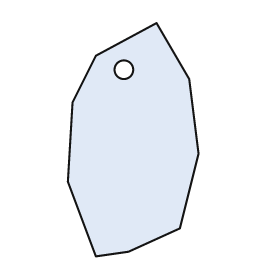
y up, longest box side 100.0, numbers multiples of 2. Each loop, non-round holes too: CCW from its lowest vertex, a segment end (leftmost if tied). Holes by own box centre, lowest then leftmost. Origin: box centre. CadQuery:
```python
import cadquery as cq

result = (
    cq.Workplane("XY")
    .moveTo(-16.0, -50.0)
    .lineTo(-2.0, -48.0)
    .lineTo(20.0, -38.0)
    .lineTo(28.0, -6.0)
    .lineTo(24.0, 26.0)
    .lineTo(10.0, 50.0)
    .lineTo(-16.0, 36.0)
    .lineTo(-26.0, 16.0)
    .lineTo(-28.0, -18.0)
    .close()
    .moveTo(-4.0, 30.0)
    .circle(4.0)
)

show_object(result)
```